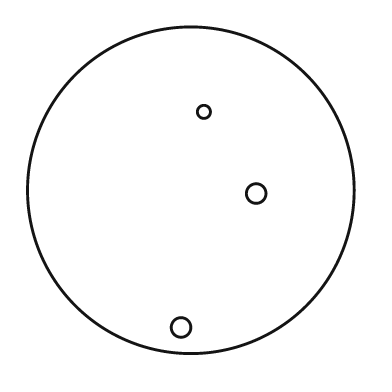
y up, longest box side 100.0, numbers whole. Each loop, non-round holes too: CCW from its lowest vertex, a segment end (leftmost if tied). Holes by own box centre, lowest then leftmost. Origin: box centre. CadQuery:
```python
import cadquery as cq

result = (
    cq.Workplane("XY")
    .moveTo(0.0, 0.0)
    .circle(50.0)
    .moveTo(-3.0, -42.0)
    .circle(3.0)
    .moveTo(20.0, -1.0)
    .circle(3.0)
    .moveTo(4.0, 24.0)
    .circle(2.0)
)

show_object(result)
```